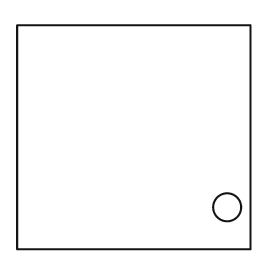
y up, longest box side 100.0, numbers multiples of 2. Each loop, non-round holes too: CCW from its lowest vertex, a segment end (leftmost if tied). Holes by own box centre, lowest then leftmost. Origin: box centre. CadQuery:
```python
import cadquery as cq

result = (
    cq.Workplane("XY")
    .moveTo(-50.0, -48.0)
    .lineTo(50.0, -48.0)
    .lineTo(50.0, 48.0)
    .lineTo(-50.0, 48.0)
    .close()
    .moveTo(40.0, -30.0)
    .circle(6.0)
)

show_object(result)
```